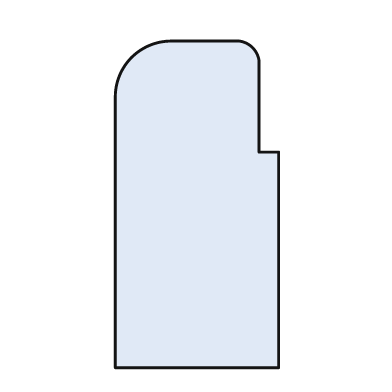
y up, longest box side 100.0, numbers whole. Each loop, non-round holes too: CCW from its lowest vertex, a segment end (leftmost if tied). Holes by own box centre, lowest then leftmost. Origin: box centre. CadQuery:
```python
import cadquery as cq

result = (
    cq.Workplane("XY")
    .moveTo(-25.0, -50.0)
    .lineTo(25.0, -50.0)
    .lineTo(25.0, 16.0)
    .lineTo(19.0, 16.0)
    .lineTo(19.0, 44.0)
    .threePointArc((17.0, 48.0), (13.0, 50.0))
    .lineTo(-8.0, 50.0)
    .threePointArc((-20.0, 45.0), (-25.0, 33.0))
    .close()
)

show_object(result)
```